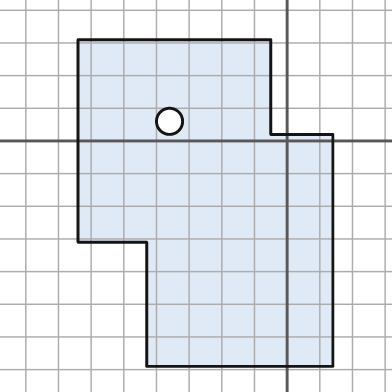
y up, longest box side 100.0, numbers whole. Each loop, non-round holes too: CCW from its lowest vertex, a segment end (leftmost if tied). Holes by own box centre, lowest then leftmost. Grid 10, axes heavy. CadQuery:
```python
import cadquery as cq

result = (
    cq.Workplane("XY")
    .moveTo(-43.0, -69.0)
    .lineTo(14.0, -69.0)
    .lineTo(14.0, 2.0)
    .lineTo(-5.0, 2.0)
    .lineTo(-5.0, 31.0)
    .lineTo(-64.0, 31.0)
    .lineTo(-64.0, -31.0)
    .lineTo(-43.0, -31.0)
    .close()
    .moveTo(-36.0, 6.0)
    .circle(4.0)
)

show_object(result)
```